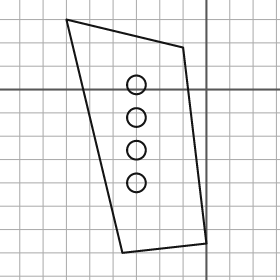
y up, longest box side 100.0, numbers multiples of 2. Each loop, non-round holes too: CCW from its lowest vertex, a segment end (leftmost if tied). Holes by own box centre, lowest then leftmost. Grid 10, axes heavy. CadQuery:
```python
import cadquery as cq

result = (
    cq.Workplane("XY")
    .moveTo(-36.0, -70.0)
    .lineTo(0.0, -66.0)
    .lineTo(-10.0, 18.0)
    .lineTo(-60.0, 30.0)
    .close()
    .moveTo(-30.0, -40.0)
    .circle(4.0)
    .moveTo(-30.0, -26.0)
    .circle(4.0)
    .moveTo(-30.0, -12.0)
    .circle(4.0)
    .moveTo(-30.0, 2.0)
    .circle(4.0)
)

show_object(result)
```